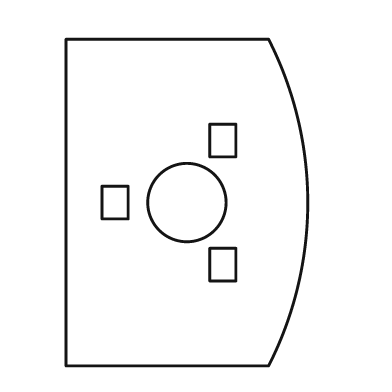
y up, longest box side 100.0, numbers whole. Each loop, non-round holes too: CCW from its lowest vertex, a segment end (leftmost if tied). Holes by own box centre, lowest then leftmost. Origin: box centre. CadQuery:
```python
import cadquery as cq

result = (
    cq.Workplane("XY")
    .moveTo(-37.0, -50.0)
    .lineTo(25.0, -50.0)
    .threePointArc((37.0, 0.0), (25.0, 50.0))
    .lineTo(-37.0, 50.0)
    .close()
    .moveTo(7.0, -24.0)
    .lineTo(15.0, -24.0)
    .lineTo(15.0, -14.0)
    .lineTo(7.0, -14.0)
    .close()
    .moveTo(-26.0, -5.0)
    .lineTo(-18.0, -5.0)
    .lineTo(-18.0, 5.0)
    .lineTo(-26.0, 5.0)
    .close()
    .moveTo(0.0, 0.0)
    .circle(12.0)
    .moveTo(7.0, 14.0)
    .lineTo(15.0, 14.0)
    .lineTo(15.0, 24.0)
    .lineTo(7.0, 24.0)
    .close()
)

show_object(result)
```